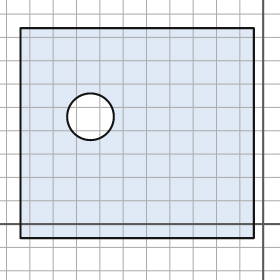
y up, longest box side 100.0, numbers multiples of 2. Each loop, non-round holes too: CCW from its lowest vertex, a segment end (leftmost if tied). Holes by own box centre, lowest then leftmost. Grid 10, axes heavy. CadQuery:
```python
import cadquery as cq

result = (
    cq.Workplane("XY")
    .moveTo(-104.0, -6.0)
    .lineTo(-4.0, -6.0)
    .lineTo(-4.0, 84.0)
    .lineTo(-104.0, 84.0)
    .close()
    .moveTo(-74.0, 46.0)
    .circle(10.0)
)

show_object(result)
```